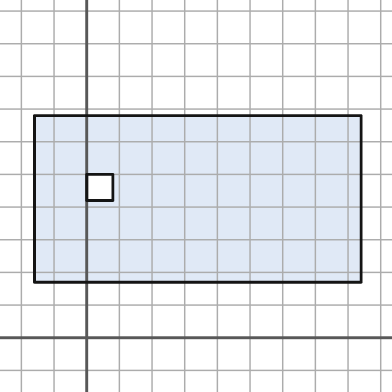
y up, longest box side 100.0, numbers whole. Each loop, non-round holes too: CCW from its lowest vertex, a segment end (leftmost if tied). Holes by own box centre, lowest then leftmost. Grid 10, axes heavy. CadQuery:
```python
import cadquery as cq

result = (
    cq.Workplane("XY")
    .moveTo(-16.0, 17.0)
    .lineTo(84.0, 17.0)
    .lineTo(84.0, 68.0)
    .lineTo(-16.0, 68.0)
    .close()
    .moveTo(0.0, 42.0)
    .lineTo(8.0, 42.0)
    .lineTo(8.0, 50.0)
    .lineTo(0.0, 50.0)
    .close()
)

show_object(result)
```